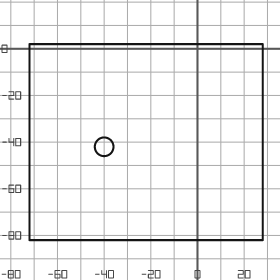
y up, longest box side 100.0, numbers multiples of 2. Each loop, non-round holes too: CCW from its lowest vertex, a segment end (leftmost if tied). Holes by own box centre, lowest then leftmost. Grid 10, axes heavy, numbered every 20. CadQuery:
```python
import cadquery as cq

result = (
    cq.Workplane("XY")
    .moveTo(-72.0, -82.0)
    .lineTo(28.0, -82.0)
    .lineTo(28.0, 2.0)
    .lineTo(-72.0, 2.0)
    .close()
    .moveTo(-40.0, -42.0)
    .circle(4.0)
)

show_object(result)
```